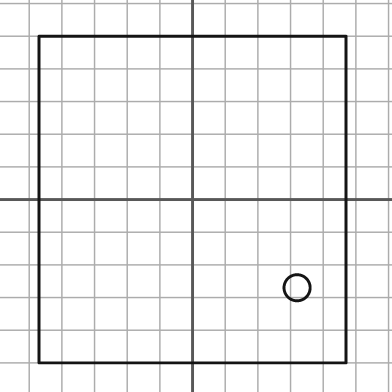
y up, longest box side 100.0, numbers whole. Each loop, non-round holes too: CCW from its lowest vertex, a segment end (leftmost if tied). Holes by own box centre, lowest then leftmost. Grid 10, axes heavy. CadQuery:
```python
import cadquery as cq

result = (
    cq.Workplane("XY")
    .moveTo(-47.0, -50.0)
    .lineTo(47.0, -50.0)
    .lineTo(47.0, 50.0)
    .lineTo(-47.0, 50.0)
    .close()
    .moveTo(32.0, -27.0)
    .circle(4.0)
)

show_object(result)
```